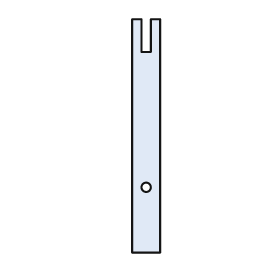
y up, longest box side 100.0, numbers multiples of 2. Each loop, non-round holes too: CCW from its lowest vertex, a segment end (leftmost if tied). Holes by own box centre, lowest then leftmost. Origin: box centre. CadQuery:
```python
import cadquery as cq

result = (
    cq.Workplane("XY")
    .moveTo(-6.0, -50.0)
    .lineTo(6.0, -50.0)
    .lineTo(6.0, 50.0)
    .lineTo(2.0, 50.0)
    .lineTo(2.0, 36.0)
    .lineTo(-2.0, 36.0)
    .lineTo(-2.0, 50.0)
    .lineTo(-6.0, 50.0)
    .close()
    .moveTo(0.0, -22.0)
    .circle(2.0)
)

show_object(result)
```